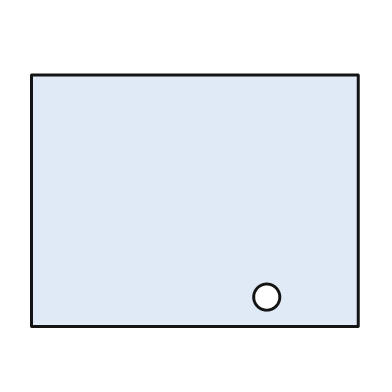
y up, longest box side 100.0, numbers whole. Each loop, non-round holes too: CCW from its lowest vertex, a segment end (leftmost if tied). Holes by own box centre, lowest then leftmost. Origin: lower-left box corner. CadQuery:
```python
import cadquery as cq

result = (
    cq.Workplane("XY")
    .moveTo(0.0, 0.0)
    .lineTo(100.0, 0.0)
    .lineTo(100.0, 77.0)
    .lineTo(0.0, 77.0)
    .close()
    .moveTo(72.0, 9.0)
    .circle(4.0)
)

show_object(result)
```